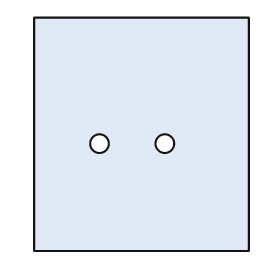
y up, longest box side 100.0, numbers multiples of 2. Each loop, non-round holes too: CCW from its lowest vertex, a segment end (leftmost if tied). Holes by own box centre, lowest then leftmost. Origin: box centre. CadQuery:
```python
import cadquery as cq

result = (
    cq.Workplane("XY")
    .moveTo(-46.0, -50.0)
    .lineTo(46.0, -50.0)
    .lineTo(46.0, 50.0)
    .lineTo(-46.0, 50.0)
    .close()
    .moveTo(-18.0, -4.0)
    .circle(4.0)
    .moveTo(10.0, -4.0)
    .circle(4.0)
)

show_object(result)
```